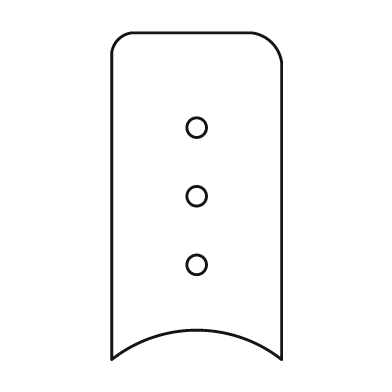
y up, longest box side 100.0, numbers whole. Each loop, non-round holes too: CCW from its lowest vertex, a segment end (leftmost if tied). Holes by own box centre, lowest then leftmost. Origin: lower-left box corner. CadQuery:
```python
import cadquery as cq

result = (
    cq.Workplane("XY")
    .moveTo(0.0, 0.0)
    .threePointArc((26.0, 9.0), (52.0, 0.0))
    .lineTo(52.0, 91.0)
    .threePointArc((49.0, 97.0), (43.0, 100.0))
    .lineTo(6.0, 100.0)
    .threePointArc((2.0, 98.0), (0.0, 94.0))
    .close()
    .moveTo(26.0, 29.0)
    .circle(3.0)
    .moveTo(26.0, 50.0)
    .circle(3.0)
    .moveTo(26.0, 71.0)
    .circle(3.0)
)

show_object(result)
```